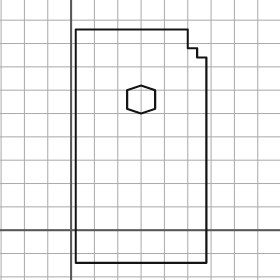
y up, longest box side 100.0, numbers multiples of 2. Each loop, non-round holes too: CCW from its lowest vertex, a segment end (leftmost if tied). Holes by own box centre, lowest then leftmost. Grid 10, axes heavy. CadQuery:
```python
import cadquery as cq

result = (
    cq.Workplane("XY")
    .moveTo(2.0, -14.0)
    .lineTo(58.0, -14.0)
    .lineTo(58.0, 74.0)
    .lineTo(54.0, 74.0)
    .lineTo(54.0, 78.0)
    .lineTo(50.0, 78.0)
    .lineTo(50.0, 86.0)
    .lineTo(2.0, 86.0)
    .close()
    .moveTo(30.0, 50.0)
    .lineTo(36.0, 52.0)
    .lineTo(36.0, 60.0)
    .lineTo(30.0, 62.0)
    .lineTo(24.0, 60.0)
    .lineTo(24.0, 52.0)
    .close()
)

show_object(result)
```